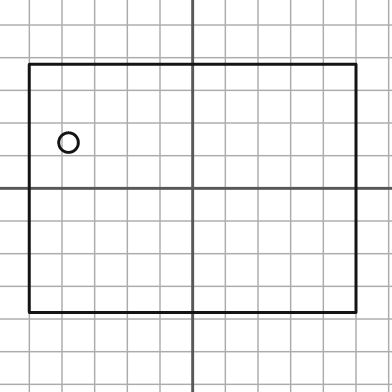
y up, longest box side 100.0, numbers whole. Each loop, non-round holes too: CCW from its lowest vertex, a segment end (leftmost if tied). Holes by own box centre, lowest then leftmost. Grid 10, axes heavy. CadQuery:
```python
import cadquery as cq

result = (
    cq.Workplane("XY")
    .moveTo(-50.0, -38.0)
    .lineTo(50.0, -38.0)
    .lineTo(50.0, 38.0)
    .lineTo(-50.0, 38.0)
    .close()
    .moveTo(-38.0, 14.0)
    .circle(3.0)
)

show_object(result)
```